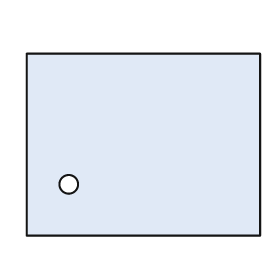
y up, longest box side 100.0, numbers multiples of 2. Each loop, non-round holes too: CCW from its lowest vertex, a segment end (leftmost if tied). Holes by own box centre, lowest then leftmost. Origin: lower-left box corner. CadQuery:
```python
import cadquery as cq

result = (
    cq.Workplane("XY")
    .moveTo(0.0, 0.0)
    .lineTo(100.0, 0.0)
    .lineTo(100.0, 78.0)
    .lineTo(0.0, 78.0)
    .close()
    .moveTo(18.0, 22.0)
    .circle(4.0)
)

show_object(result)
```